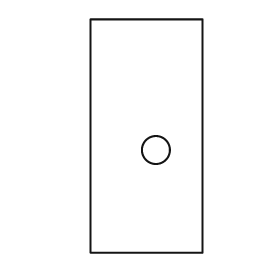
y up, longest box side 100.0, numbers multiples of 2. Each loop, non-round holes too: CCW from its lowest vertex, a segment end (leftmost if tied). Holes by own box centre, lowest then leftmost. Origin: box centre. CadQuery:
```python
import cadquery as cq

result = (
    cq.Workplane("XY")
    .moveTo(-24.0, -50.0)
    .lineTo(24.0, -50.0)
    .lineTo(24.0, 50.0)
    .lineTo(-24.0, 50.0)
    .close()
    .moveTo(4.0, -6.0)
    .circle(6.0)
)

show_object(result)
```